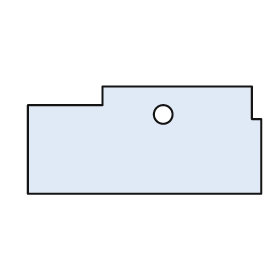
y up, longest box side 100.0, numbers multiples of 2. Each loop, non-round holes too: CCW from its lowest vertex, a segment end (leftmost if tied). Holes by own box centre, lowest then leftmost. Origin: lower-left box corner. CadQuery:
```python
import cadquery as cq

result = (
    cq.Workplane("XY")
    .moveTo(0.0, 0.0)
    .lineTo(100.0, 0.0)
    .lineTo(100.0, 32.0)
    .lineTo(96.0, 32.0)
    .lineTo(96.0, 46.0)
    .lineTo(32.0, 46.0)
    .lineTo(32.0, 38.0)
    .lineTo(0.0, 38.0)
    .close()
    .moveTo(58.0, 34.0)
    .circle(4.0)
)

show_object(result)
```